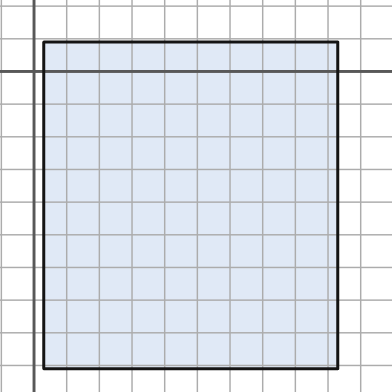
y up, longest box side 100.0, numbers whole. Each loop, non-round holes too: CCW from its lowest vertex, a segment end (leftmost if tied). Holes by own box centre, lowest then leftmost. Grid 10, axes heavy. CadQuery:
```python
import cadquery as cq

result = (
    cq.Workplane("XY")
    .moveTo(3.0, -91.0)
    .lineTo(93.0, -91.0)
    .lineTo(93.0, 9.0)
    .lineTo(3.0, 9.0)
    .close()
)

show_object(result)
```